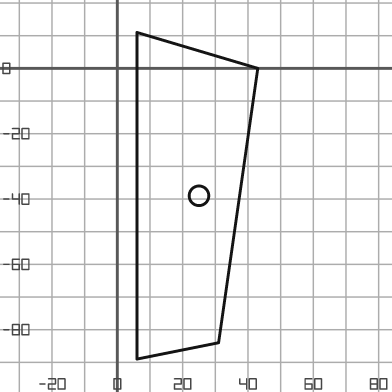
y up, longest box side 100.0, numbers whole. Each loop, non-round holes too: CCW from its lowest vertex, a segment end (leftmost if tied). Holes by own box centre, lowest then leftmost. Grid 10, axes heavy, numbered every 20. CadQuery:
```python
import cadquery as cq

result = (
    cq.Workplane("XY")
    .moveTo(6.0, -89.0)
    .lineTo(31.0, -84.0)
    .lineTo(43.0, 0.0)
    .lineTo(6.0, 11.0)
    .close()
    .moveTo(25.0, -39.0)
    .circle(3.0)
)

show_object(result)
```